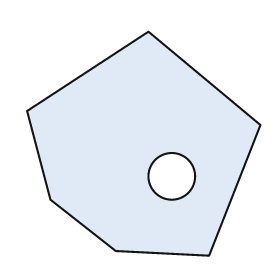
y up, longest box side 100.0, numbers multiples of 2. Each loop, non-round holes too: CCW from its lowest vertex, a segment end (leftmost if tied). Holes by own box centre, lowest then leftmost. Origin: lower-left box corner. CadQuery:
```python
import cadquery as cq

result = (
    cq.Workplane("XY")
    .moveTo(78.0, 0.0)
    .lineTo(100.0, 56.0)
    .lineTo(52.0, 96.0)
    .lineTo(0.0, 62.0)
    .lineTo(10.0, 24.0)
    .lineTo(38.0, 2.0)
    .close()
    .moveTo(62.0, 34.0)
    .circle(10.0)
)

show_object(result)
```